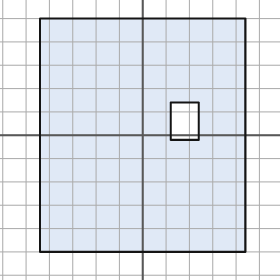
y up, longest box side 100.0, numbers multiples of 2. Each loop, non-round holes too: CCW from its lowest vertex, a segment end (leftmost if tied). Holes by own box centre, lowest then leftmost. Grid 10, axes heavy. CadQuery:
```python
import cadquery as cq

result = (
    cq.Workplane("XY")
    .moveTo(-44.0, -50.0)
    .lineTo(44.0, -50.0)
    .lineTo(44.0, 50.0)
    .lineTo(-44.0, 50.0)
    .close()
    .moveTo(12.0, -2.0)
    .lineTo(24.0, -2.0)
    .lineTo(24.0, 14.0)
    .lineTo(12.0, 14.0)
    .close()
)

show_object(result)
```